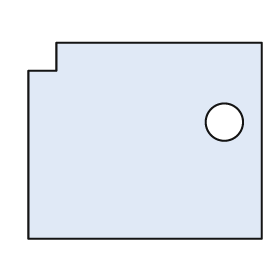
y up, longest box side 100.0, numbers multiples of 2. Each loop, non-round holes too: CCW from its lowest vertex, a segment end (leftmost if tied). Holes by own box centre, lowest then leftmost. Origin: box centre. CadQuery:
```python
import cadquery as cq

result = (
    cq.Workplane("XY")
    .moveTo(-50.0, -42.0)
    .lineTo(50.0, -42.0)
    .lineTo(50.0, 42.0)
    .lineTo(-38.0, 42.0)
    .lineTo(-38.0, 30.0)
    .lineTo(-50.0, 30.0)
    .close()
    .moveTo(34.0, 8.0)
    .circle(8.0)
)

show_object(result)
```